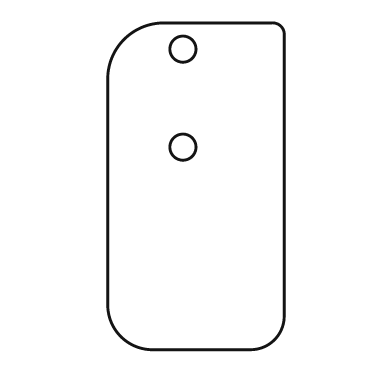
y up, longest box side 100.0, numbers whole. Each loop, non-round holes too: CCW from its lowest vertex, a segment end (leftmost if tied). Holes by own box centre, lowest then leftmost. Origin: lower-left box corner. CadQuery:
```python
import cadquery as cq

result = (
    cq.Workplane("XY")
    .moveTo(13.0, 0.0)
    .lineTo(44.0, 0.0)
    .threePointArc((51.0, 3.0), (54.0, 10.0))
    .lineTo(54.0, 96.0)
    .threePointArc((53.0, 99.0), (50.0, 100.0))
    .lineTo(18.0, 100.0)
    .threePointArc((5.0, 95.0), (0.0, 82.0))
    .lineTo(0.0, 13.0)
    .threePointArc((4.0, 4.0), (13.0, 0.0))
    .close()
    .moveTo(23.0, 62.0)
    .circle(4.0)
    .moveTo(23.0, 92.0)
    .circle(4.0)
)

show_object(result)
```